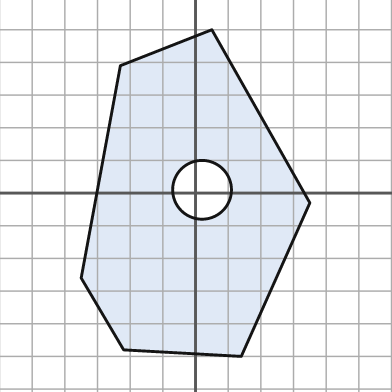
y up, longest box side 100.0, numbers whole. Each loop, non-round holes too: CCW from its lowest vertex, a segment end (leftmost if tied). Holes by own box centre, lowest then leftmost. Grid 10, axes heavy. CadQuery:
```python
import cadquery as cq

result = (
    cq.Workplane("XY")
    .moveTo(14.0, -50.0)
    .lineTo(35.0, -3.0)
    .lineTo(5.0, 50.0)
    .lineTo(-23.0, 39.0)
    .lineTo(-35.0, -26.0)
    .lineTo(-22.0, -48.0)
    .close()
    .moveTo(2.0, 1.0)
    .circle(9.0)
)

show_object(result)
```